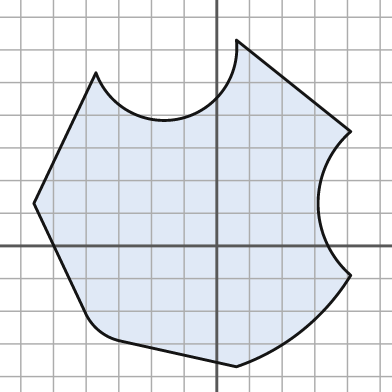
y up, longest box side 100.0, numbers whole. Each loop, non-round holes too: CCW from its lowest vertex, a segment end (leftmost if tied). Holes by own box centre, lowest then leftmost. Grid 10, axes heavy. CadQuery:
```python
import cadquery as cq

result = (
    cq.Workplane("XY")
    .moveTo(6.0, -37.0)
    .threePointArc((26.0, -26.0), (41.0, -9.0))
    .threePointArc((31.0, 13.0), (41.0, 35.0))
    .lineTo(6.0, 63.0)
    .threePointArc((-11.0, 39.0), (-37.0, 53.0))
    .lineTo(-56.0, 13.0)
    .lineTo(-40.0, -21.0)
    .threePointArc((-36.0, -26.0), (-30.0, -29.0))
    .close()
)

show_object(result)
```